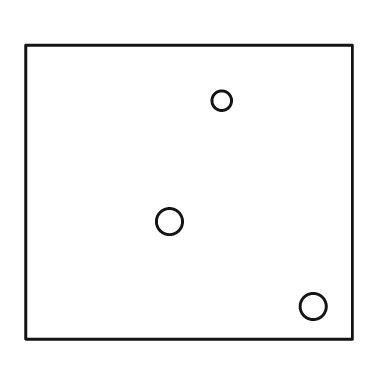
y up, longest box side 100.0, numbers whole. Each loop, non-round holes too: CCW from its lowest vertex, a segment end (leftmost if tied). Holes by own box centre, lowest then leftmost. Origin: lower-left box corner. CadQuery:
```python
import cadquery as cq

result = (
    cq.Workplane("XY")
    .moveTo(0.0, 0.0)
    .lineTo(100.0, 0.0)
    .lineTo(100.0, 90.0)
    .lineTo(0.0, 90.0)
    .close()
    .moveTo(88.0, 10.0)
    .circle(4.0)
    .moveTo(44.0, 36.0)
    .circle(4.0)
    .moveTo(60.0, 73.0)
    .circle(3.0)
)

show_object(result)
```